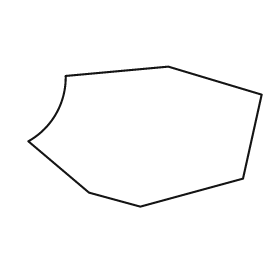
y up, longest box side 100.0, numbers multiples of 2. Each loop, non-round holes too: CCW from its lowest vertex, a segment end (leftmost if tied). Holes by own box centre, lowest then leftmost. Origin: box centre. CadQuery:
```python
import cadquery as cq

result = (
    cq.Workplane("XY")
    .moveTo(-2.0, -30.0)
    .lineTo(42.0, -18.0)
    .lineTo(50.0, 18.0)
    .lineTo(10.0, 30.0)
    .lineTo(-34.0, 26.0)
    .threePointArc((-38.0, 10.0), (-50.0, -2.0))
    .lineTo(-24.0, -24.0)
    .close()
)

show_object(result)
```